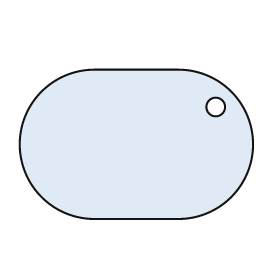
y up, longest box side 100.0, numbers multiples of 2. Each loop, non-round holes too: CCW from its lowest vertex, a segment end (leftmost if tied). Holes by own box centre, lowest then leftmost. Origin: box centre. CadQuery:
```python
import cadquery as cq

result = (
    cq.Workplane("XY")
    .moveTo(-18.0, -32.0)
    .lineTo(18.0, -32.0)
    .threePointArc((50.0, 0.0), (18.0, 32.0))
    .lineTo(-18.0, 32.0)
    .threePointArc((-50.0, 0.0), (-18.0, -32.0))
    .close()
    .moveTo(34.0, 16.0)
    .circle(4.0)
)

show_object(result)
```